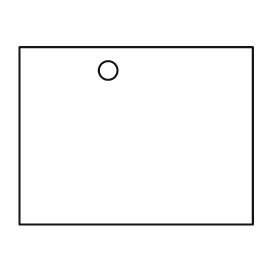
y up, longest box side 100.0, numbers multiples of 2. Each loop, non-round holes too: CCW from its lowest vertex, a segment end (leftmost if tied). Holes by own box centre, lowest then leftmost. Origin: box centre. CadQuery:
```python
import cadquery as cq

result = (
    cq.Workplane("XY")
    .moveTo(-50.0, -38.0)
    .lineTo(50.0, -38.0)
    .lineTo(50.0, 38.0)
    .lineTo(-50.0, 38.0)
    .close()
    .moveTo(-12.0, 28.0)
    .circle(4.0)
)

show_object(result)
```